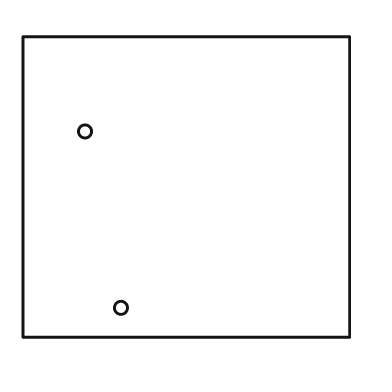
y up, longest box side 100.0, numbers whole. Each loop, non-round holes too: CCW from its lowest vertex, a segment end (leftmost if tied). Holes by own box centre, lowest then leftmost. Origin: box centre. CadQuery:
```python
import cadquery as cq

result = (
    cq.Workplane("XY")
    .moveTo(-50.0, -46.0)
    .lineTo(50.0, -46.0)
    .lineTo(50.0, 46.0)
    .lineTo(-50.0, 46.0)
    .close()
    .moveTo(-20.0, -37.0)
    .circle(2.0)
    .moveTo(-31.0, 17.0)
    .circle(2.0)
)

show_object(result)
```